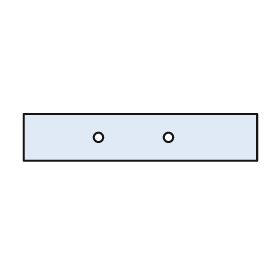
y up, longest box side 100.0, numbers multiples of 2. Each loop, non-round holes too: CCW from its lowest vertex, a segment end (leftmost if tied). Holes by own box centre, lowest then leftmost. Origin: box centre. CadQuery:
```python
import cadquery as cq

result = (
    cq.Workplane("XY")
    .moveTo(-50.0, -10.0)
    .lineTo(50.0, -10.0)
    .lineTo(50.0, 10.0)
    .lineTo(-50.0, 10.0)
    .close()
    .moveTo(-18.0, 0.0)
    .circle(2.0)
    .moveTo(12.0, 0.0)
    .circle(2.0)
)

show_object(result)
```